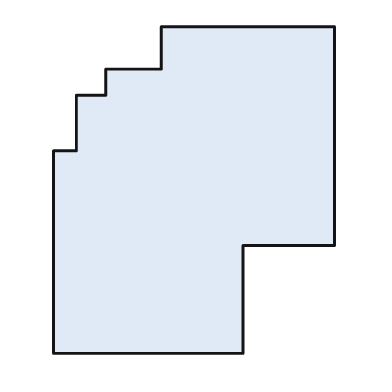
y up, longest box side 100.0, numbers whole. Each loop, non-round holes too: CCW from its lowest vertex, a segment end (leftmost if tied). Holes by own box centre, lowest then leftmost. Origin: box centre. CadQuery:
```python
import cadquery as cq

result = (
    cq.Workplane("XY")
    .moveTo(-43.0, -50.0)
    .lineTo(15.0, -50.0)
    .lineTo(15.0, -17.0)
    .lineTo(43.0, -17.0)
    .lineTo(43.0, 50.0)
    .lineTo(-10.0, 50.0)
    .lineTo(-10.0, 37.0)
    .lineTo(-27.0, 37.0)
    .lineTo(-27.0, 29.0)
    .lineTo(-36.0, 29.0)
    .lineTo(-36.0, 12.0)
    .lineTo(-43.0, 12.0)
    .close()
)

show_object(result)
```